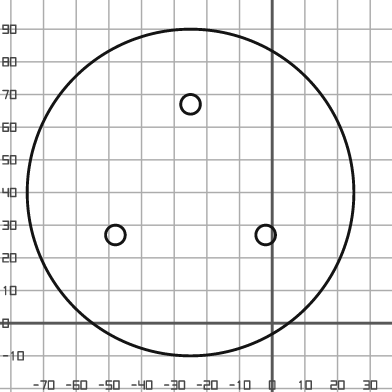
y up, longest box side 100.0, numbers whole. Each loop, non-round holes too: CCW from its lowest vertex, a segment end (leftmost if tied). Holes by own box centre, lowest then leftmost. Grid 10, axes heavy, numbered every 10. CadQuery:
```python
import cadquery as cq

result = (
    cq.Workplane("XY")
    .moveTo(-25.0, 40.0)
    .circle(50.0)
    .moveTo(-48.0, 27.0)
    .circle(3.0)
    .moveTo(-2.0, 27.0)
    .circle(3.0)
    .moveTo(-25.0, 67.0)
    .circle(3.0)
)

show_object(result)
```